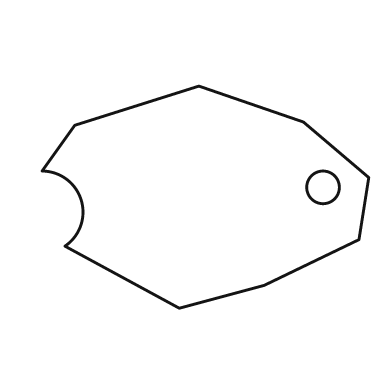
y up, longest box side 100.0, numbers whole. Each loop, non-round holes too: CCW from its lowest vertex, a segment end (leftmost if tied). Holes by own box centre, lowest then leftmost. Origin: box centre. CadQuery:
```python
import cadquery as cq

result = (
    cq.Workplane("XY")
    .moveTo(-8.0, -34.0)
    .lineTo(18.0, -27.0)
    .lineTo(47.0, -13.0)
    .lineTo(50.0, 6.0)
    .lineTo(30.0, 23.0)
    .lineTo(-2.0, 34.0)
    .lineTo(-40.0, 22.0)
    .lineTo(-50.0, 8.0)
    .threePointArc((-38.0, -1.0), (-43.0, -15.0))
    .close()
    .moveTo(36.0, 3.0)
    .circle(5.0)
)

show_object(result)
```